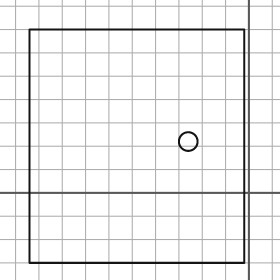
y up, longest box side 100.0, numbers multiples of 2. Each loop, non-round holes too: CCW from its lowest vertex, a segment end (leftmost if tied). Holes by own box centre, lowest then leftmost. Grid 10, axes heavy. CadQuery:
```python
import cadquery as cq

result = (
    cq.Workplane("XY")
    .moveTo(-94.0, -30.0)
    .lineTo(-2.0, -30.0)
    .lineTo(-2.0, 70.0)
    .lineTo(-94.0, 70.0)
    .close()
    .moveTo(-26.0, 22.0)
    .circle(4.0)
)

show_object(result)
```